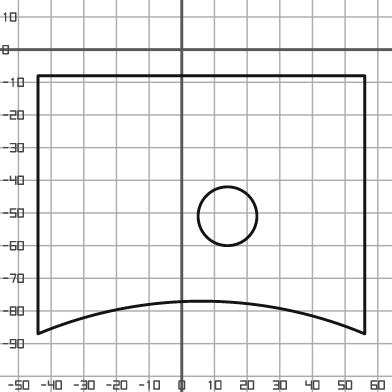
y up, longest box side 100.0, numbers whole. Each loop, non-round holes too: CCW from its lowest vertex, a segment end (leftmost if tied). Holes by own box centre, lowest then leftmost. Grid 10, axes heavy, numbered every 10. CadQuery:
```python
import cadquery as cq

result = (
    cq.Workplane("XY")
    .moveTo(-44.0, -87.0)
    .threePointArc((6.0, -77.0), (56.0, -87.0))
    .lineTo(56.0, -8.0)
    .lineTo(-44.0, -8.0)
    .close()
    .moveTo(14.0, -51.0)
    .circle(9.0)
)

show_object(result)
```